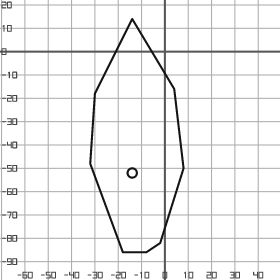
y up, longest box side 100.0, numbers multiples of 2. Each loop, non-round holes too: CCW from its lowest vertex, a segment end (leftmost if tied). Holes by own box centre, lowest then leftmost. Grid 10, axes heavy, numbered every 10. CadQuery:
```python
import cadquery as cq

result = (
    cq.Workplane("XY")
    .moveTo(-18.0, -86.0)
    .lineTo(-8.0, -86.0)
    .lineTo(-2.0, -82.0)
    .lineTo(8.0, -50.0)
    .lineTo(4.0, -16.0)
    .lineTo(-14.0, 14.0)
    .lineTo(-30.0, -18.0)
    .lineTo(-32.0, -48.0)
    .close()
    .moveTo(-14.0, -52.0)
    .circle(2.0)
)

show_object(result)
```